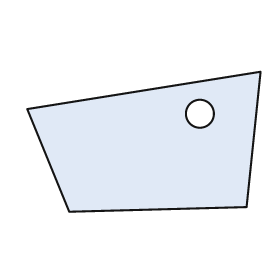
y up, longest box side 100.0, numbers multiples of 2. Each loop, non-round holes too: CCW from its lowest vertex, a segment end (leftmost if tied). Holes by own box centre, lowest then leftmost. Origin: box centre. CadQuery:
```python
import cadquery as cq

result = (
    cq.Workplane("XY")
    .moveTo(-32.0, -30.0)
    .lineTo(44.0, -28.0)
    .lineTo(50.0, 30.0)
    .lineTo(-50.0, 14.0)
    .close()
    .moveTo(24.0, 12.0)
    .circle(6.0)
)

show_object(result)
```